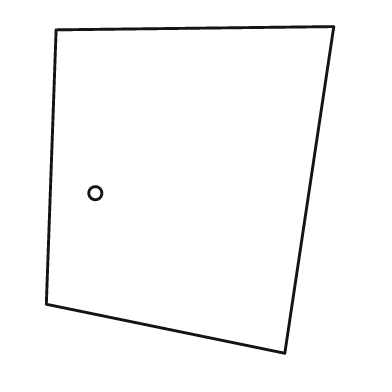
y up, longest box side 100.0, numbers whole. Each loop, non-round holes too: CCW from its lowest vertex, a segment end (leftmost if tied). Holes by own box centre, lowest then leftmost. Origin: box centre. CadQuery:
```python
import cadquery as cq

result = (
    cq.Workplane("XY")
    .moveTo(29.0, -50.0)
    .lineTo(44.0, 50.0)
    .lineTo(-41.0, 49.0)
    .lineTo(-44.0, -35.0)
    .close()
    .moveTo(-29.0, -1.0)
    .circle(2.0)
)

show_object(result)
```